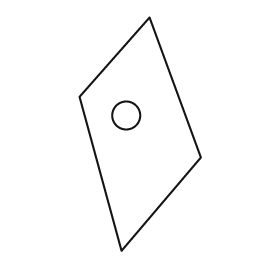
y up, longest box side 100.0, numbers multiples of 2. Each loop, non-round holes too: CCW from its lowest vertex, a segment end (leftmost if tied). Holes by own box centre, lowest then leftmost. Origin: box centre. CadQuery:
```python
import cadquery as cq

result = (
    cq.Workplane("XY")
    .moveTo(-8.0, -50.0)
    .lineTo(26.0, -10.0)
    .lineTo(4.0, 50.0)
    .lineTo(-26.0, 16.0)
    .close()
    .moveTo(-6.0, 8.0)
    .circle(6.0)
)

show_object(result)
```